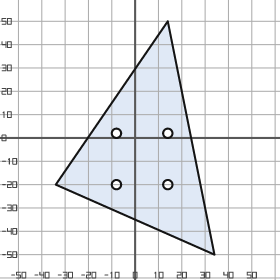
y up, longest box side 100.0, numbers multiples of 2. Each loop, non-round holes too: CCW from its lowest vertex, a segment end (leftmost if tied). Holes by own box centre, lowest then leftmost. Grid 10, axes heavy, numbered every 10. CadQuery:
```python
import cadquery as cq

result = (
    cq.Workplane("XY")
    .moveTo(34.0, -50.0)
    .lineTo(14.0, 50.0)
    .lineTo(-34.0, -20.0)
    .close()
    .moveTo(-8.0, -20.0)
    .circle(2.0)
    .moveTo(14.0, -20.0)
    .circle(2.0)
    .moveTo(-8.0, 2.0)
    .circle(2.0)
    .moveTo(14.0, 2.0)
    .circle(2.0)
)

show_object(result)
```